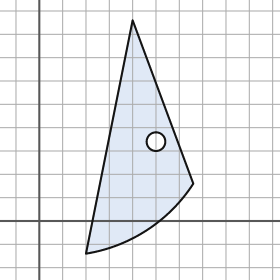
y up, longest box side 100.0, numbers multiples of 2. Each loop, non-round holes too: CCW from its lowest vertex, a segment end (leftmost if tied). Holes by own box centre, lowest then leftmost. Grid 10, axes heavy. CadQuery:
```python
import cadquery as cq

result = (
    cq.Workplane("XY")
    .moveTo(20.0, -14.0)
    .threePointArc((46.0, -4.0), (66.0, 16.0))
    .lineTo(40.0, 86.0)
    .close()
    .moveTo(50.0, 34.0)
    .circle(4.0)
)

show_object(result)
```